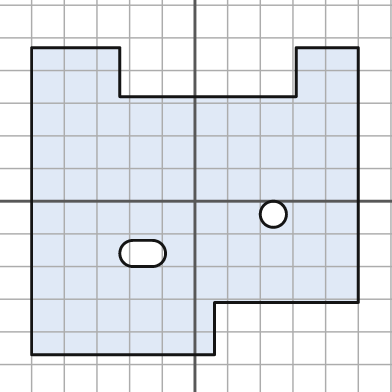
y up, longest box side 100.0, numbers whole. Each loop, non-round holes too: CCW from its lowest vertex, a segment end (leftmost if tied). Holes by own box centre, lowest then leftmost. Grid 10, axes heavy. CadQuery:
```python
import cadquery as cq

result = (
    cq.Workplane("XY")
    .moveTo(-50.0, -47.0)
    .lineTo(6.0, -47.0)
    .lineTo(6.0, -31.0)
    .lineTo(50.0, -31.0)
    .lineTo(50.0, 47.0)
    .lineTo(31.0, 47.0)
    .lineTo(31.0, 32.0)
    .lineTo(-23.0, 32.0)
    .lineTo(-23.0, 47.0)
    .lineTo(-50.0, 47.0)
    .close()
    .moveTo(-19.0, -20.0)
    .lineTo(-13.0, -20.0)
    .threePointArc((-9.0, -16.0), (-13.0, -12.0))
    .lineTo(-19.0, -12.0)
    .threePointArc((-23.0, -16.0), (-19.0, -20.0))
    .close()
    .moveTo(24.0, -4.0)
    .circle(4.0)
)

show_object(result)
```